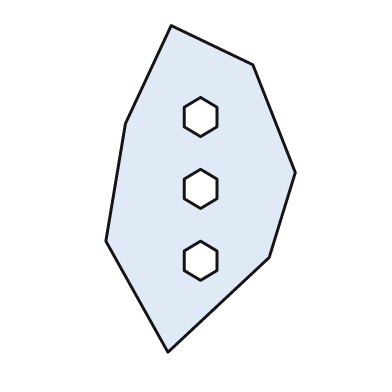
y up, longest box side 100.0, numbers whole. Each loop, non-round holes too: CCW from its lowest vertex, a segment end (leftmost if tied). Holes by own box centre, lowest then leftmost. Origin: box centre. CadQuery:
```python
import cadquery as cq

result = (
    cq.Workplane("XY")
    .moveTo(-10.0, -50.0)
    .lineTo(21.0, -21.0)
    .lineTo(29.0, 5.0)
    .lineTo(16.0, 38.0)
    .lineTo(-9.0, 50.0)
    .lineTo(-23.0, 20.0)
    .lineTo(-29.0, -16.0)
    .close()
    .moveTo(0.0, -28.0)
    .lineTo(5.0, -25.0)
    .lineTo(5.0, -19.0)
    .lineTo(0.0, -16.0)
    .lineTo(-5.0, -19.0)
    .lineTo(-5.0, -25.0)
    .close()
    .moveTo(0.0, -6.0)
    .lineTo(5.0, -3.0)
    .lineTo(5.0, 3.0)
    .lineTo(0.0, 6.0)
    .lineTo(-5.0, 3.0)
    .lineTo(-5.0, -3.0)
    .close()
    .moveTo(0.0, 16.0)
    .lineTo(5.0, 19.0)
    .lineTo(5.0, 25.0)
    .lineTo(0.0, 28.0)
    .lineTo(-5.0, 25.0)
    .lineTo(-5.0, 19.0)
    .close()
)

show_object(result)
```